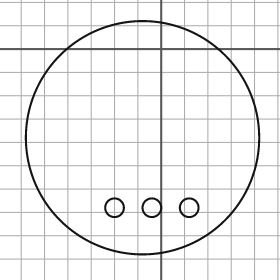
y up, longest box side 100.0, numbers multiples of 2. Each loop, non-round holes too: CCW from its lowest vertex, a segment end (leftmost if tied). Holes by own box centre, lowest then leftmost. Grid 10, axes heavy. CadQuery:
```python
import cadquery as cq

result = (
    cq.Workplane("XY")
    .moveTo(-8.0, -38.0)
    .circle(50.0)
    .moveTo(-20.0, -68.0)
    .circle(4.0)
    .moveTo(-4.0, -68.0)
    .circle(4.0)
    .moveTo(12.0, -68.0)
    .circle(4.0)
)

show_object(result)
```